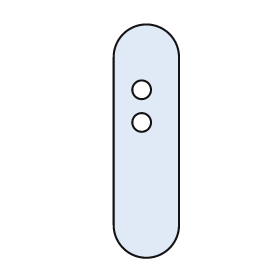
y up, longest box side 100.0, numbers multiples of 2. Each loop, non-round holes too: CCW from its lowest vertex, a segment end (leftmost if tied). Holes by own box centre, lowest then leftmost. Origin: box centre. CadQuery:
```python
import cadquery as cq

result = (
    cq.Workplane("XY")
    .moveTo(-14.0, -36.0)
    .threePointArc((0.0, -50.0), (14.0, -36.0))
    .lineTo(14.0, 36.0)
    .threePointArc((0.0, 50.0), (-14.0, 36.0))
    .close()
    .moveTo(-2.0, 8.0)
    .circle(4.0)
    .moveTo(-2.0, 22.0)
    .circle(4.0)
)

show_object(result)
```